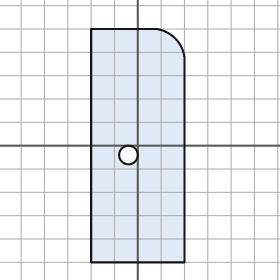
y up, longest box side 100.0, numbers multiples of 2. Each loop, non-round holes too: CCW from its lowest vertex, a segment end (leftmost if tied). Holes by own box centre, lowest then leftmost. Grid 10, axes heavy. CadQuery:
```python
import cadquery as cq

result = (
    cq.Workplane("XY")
    .moveTo(-20.0, -50.0)
    .lineTo(20.0, -50.0)
    .lineTo(20.0, 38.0)
    .threePointArc((16.0, 46.0), (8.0, 50.0))
    .lineTo(-20.0, 50.0)
    .close()
    .moveTo(-4.0, -4.0)
    .circle(4.0)
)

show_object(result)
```